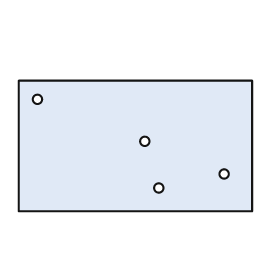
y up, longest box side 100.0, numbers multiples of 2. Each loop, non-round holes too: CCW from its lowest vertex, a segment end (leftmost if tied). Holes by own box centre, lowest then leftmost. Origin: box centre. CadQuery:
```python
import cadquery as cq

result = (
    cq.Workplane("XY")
    .moveTo(-50.0, -28.0)
    .lineTo(50.0, -28.0)
    .lineTo(50.0, 28.0)
    .lineTo(-50.0, 28.0)
    .close()
    .moveTo(10.0, -18.0)
    .circle(2.0)
    .moveTo(38.0, -12.0)
    .circle(2.0)
    .moveTo(4.0, 2.0)
    .circle(2.0)
    .moveTo(-42.0, 20.0)
    .circle(2.0)
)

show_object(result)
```